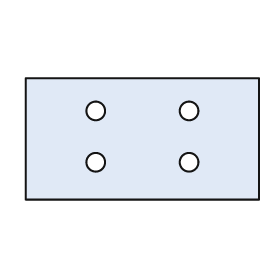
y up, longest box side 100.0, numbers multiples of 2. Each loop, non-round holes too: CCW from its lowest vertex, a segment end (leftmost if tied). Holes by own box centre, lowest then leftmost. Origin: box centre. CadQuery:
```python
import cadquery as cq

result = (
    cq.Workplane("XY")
    .moveTo(-50.0, -26.0)
    .lineTo(50.0, -26.0)
    .lineTo(50.0, 26.0)
    .lineTo(-50.0, 26.0)
    .close()
    .moveTo(-20.0, -10.0)
    .circle(4.0)
    .moveTo(20.0, -10.0)
    .circle(4.0)
    .moveTo(-20.0, 12.0)
    .circle(4.0)
    .moveTo(20.0, 12.0)
    .circle(4.0)
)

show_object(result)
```